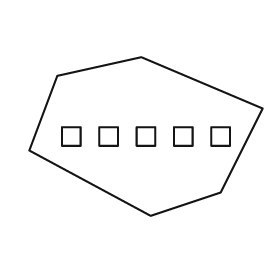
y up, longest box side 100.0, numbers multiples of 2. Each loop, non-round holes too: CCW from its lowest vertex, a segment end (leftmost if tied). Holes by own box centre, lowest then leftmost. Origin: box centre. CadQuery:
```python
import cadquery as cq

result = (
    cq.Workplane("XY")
    .moveTo(2.0, -34.0)
    .lineTo(32.0, -24.0)
    .lineTo(50.0, 12.0)
    .lineTo(-2.0, 34.0)
    .lineTo(-38.0, 26.0)
    .lineTo(-50.0, -6.0)
    .close()
    .moveTo(-36.0, -4.0)
    .lineTo(-28.0, -4.0)
    .lineTo(-28.0, 4.0)
    .lineTo(-36.0, 4.0)
    .close()
    .moveTo(-20.0, -4.0)
    .lineTo(-12.0, -4.0)
    .lineTo(-12.0, 4.0)
    .lineTo(-20.0, 4.0)
    .close()
    .moveTo(-4.0, -4.0)
    .lineTo(4.0, -4.0)
    .lineTo(4.0, 4.0)
    .lineTo(-4.0, 4.0)
    .close()
    .moveTo(12.0, -4.0)
    .lineTo(20.0, -4.0)
    .lineTo(20.0, 4.0)
    .lineTo(12.0, 4.0)
    .close()
    .moveTo(28.0, -4.0)
    .lineTo(36.0, -4.0)
    .lineTo(36.0, 4.0)
    .lineTo(28.0, 4.0)
    .close()
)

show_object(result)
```